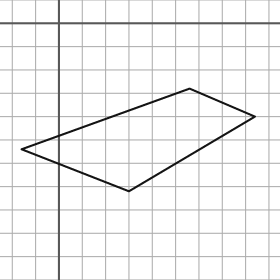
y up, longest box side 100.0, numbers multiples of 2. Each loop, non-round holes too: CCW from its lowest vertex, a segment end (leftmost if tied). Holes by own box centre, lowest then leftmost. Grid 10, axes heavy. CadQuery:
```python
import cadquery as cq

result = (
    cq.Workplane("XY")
    .moveTo(30.0, -72.0)
    .lineTo(84.0, -40.0)
    .lineTo(56.0, -28.0)
    .lineTo(-16.0, -54.0)
    .close()
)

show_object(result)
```